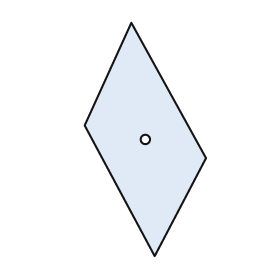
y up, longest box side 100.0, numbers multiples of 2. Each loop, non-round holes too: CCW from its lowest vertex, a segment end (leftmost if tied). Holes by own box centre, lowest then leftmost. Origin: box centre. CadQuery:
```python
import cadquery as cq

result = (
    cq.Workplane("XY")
    .moveTo(4.0, -50.0)
    .lineTo(26.0, -8.0)
    .lineTo(-6.0, 50.0)
    .lineTo(-26.0, 6.0)
    .close()
    .moveTo(0.0, 0.0)
    .circle(2.0)
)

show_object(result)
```